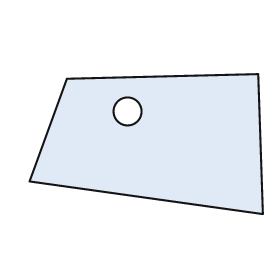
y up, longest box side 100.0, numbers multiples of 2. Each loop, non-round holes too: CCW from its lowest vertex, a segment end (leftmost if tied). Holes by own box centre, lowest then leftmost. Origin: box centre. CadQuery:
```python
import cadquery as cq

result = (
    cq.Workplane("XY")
    .moveTo(50.0, -30.0)
    .lineTo(48.0, 30.0)
    .lineTo(-34.0, 28.0)
    .lineTo(-50.0, -16.0)
    .close()
    .moveTo(-8.0, 14.0)
    .circle(6.0)
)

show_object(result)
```